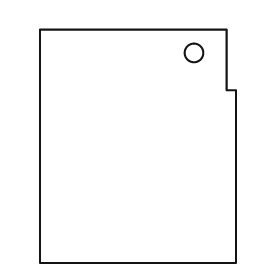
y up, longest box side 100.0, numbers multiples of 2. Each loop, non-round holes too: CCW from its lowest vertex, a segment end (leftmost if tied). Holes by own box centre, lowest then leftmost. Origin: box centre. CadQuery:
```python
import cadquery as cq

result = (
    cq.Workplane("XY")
    .moveTo(-42.0, -50.0)
    .lineTo(42.0, -50.0)
    .lineTo(42.0, 24.0)
    .lineTo(38.0, 24.0)
    .lineTo(38.0, 50.0)
    .lineTo(-42.0, 50.0)
    .close()
    .moveTo(24.0, 40.0)
    .circle(4.0)
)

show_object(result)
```